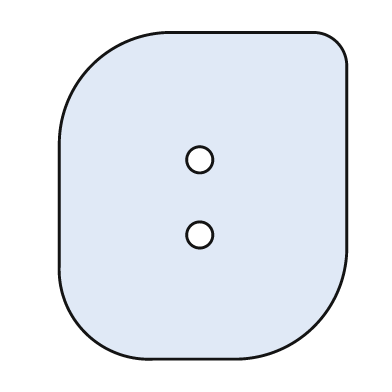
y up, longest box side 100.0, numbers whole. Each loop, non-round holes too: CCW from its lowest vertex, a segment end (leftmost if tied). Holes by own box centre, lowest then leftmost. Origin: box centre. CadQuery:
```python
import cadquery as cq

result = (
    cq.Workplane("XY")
    .moveTo(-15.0, -50.0)
    .lineTo(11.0, -50.0)
    .threePointArc((34.0, -40.0), (44.0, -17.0))
    .lineTo(44.0, 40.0)
    .threePointArc((41.0, 47.0), (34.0, 50.0))
    .lineTo(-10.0, 50.0)
    .threePointArc((-34.0, 40.0), (-44.0, 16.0))
    .lineTo(-44.0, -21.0)
    .threePointArc((-36.0, -42.0), (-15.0, -50.0))
    .close()
    .moveTo(-1.0, -12.0)
    .circle(4.0)
    .moveTo(-1.0, 11.0)
    .circle(4.0)
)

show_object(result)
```